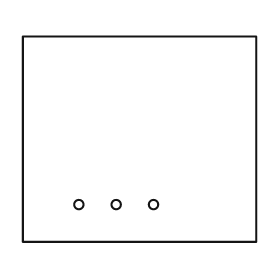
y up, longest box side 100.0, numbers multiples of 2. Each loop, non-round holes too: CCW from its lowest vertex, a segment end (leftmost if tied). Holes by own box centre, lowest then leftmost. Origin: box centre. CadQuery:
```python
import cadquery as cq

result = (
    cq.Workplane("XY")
    .moveTo(-50.0, -44.0)
    .lineTo(50.0, -44.0)
    .lineTo(50.0, 44.0)
    .lineTo(-50.0, 44.0)
    .close()
    .moveTo(-26.0, -28.0)
    .circle(2.0)
    .moveTo(-10.0, -28.0)
    .circle(2.0)
    .moveTo(6.0, -28.0)
    .circle(2.0)
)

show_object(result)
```